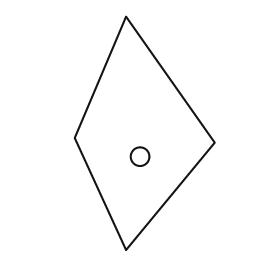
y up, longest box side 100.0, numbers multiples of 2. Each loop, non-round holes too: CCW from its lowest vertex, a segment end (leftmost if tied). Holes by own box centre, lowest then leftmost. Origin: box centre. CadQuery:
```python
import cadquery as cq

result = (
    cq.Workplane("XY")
    .moveTo(-8.0, -50.0)
    .lineTo(30.0, -4.0)
    .lineTo(-8.0, 50.0)
    .lineTo(-30.0, -2.0)
    .close()
    .moveTo(-2.0, -10.0)
    .circle(4.0)
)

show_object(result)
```